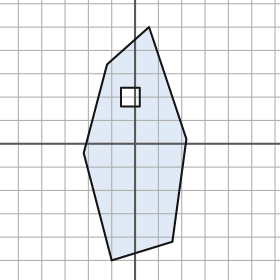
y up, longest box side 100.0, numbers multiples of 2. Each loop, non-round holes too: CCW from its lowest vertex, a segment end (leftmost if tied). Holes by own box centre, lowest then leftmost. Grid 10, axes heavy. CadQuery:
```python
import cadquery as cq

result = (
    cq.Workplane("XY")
    .moveTo(-10.0, -50.0)
    .lineTo(16.0, -42.0)
    .lineTo(22.0, 2.0)
    .lineTo(6.0, 50.0)
    .lineTo(-12.0, 34.0)
    .lineTo(-22.0, -4.0)
    .close()
    .moveTo(-6.0, 16.0)
    .lineTo(2.0, 16.0)
    .lineTo(2.0, 24.0)
    .lineTo(-6.0, 24.0)
    .close()
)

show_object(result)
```